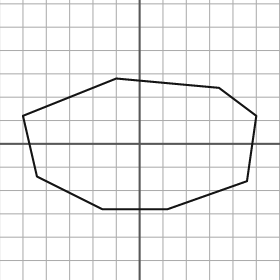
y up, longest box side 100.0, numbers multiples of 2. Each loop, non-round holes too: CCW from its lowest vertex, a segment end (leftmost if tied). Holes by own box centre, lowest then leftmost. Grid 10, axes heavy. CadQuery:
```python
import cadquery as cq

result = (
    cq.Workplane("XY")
    .moveTo(-16.0, -28.0)
    .lineTo(12.0, -28.0)
    .lineTo(46.0, -16.0)
    .lineTo(50.0, 12.0)
    .lineTo(34.0, 24.0)
    .lineTo(-10.0, 28.0)
    .lineTo(-50.0, 12.0)
    .lineTo(-44.0, -14.0)
    .close()
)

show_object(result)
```